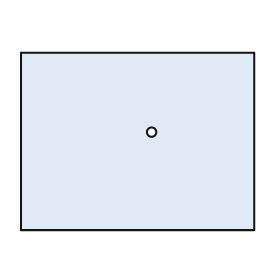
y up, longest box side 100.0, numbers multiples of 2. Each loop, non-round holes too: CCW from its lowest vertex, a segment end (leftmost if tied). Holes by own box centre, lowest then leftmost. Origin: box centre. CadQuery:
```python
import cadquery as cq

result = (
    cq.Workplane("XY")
    .moveTo(-50.0, -38.0)
    .lineTo(50.0, -38.0)
    .lineTo(50.0, 38.0)
    .lineTo(-50.0, 38.0)
    .close()
    .moveTo(6.0, 4.0)
    .circle(2.0)
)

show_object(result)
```